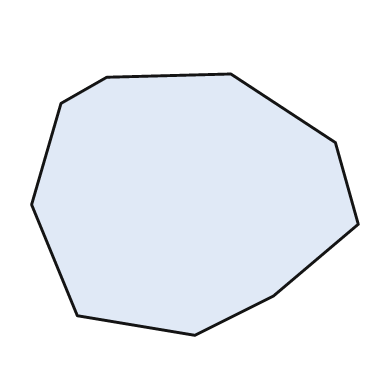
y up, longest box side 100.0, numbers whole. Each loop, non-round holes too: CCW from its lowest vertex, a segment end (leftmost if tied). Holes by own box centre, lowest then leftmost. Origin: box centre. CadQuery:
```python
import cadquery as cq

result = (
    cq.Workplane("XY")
    .moveTo(0.0, -40.0)
    .lineTo(24.0, -28.0)
    .lineTo(50.0, -6.0)
    .lineTo(43.0, 19.0)
    .lineTo(11.0, 40.0)
    .lineTo(-27.0, 39.0)
    .lineTo(-41.0, 31.0)
    .lineTo(-50.0, 0.0)
    .lineTo(-36.0, -34.0)
    .close()
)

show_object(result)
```